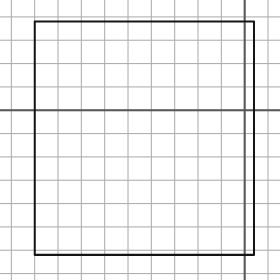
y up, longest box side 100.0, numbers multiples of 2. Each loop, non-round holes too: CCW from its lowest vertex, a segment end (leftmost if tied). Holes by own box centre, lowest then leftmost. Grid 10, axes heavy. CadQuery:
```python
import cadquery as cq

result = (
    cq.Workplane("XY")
    .moveTo(-90.0, -62.0)
    .lineTo(4.0, -62.0)
    .lineTo(4.0, 38.0)
    .lineTo(-90.0, 38.0)
    .close()
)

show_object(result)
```